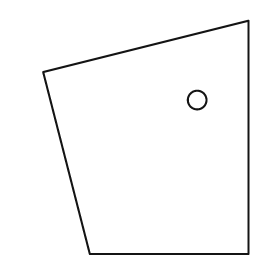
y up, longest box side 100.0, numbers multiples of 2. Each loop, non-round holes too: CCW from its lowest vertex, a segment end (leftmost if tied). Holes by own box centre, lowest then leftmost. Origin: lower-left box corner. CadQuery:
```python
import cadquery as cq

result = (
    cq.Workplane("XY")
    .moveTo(20.0, 0.0)
    .lineTo(88.0, 0.0)
    .lineTo(88.0, 100.0)
    .lineTo(0.0, 78.0)
    .close()
    .moveTo(66.0, 66.0)
    .circle(4.0)
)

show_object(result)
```